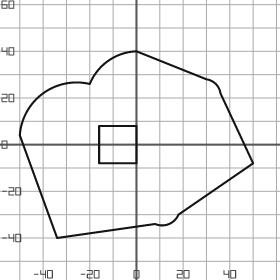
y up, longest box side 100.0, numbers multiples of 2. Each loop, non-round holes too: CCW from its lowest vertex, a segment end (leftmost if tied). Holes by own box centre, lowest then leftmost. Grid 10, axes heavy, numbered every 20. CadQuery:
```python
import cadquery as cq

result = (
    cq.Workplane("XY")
    .moveTo(-34.0, -40.0)
    .lineTo(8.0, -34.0)
    .threePointArc((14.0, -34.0), (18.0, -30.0))
    .lineTo(50.0, -8.0)
    .lineTo(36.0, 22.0)
    .threePointArc((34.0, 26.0), (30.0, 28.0))
    .lineTo(0.0, 40.0)
    .threePointArc((-12.0, 36.0), (-20.0, 26.0))
    .threePointArc((-40.0, 22.0), (-50.0, 4.0))
    .close()
    .moveTo(-16.0, -8.0)
    .lineTo(0.0, -8.0)
    .lineTo(0.0, 8.0)
    .lineTo(-16.0, 8.0)
    .close()
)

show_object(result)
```